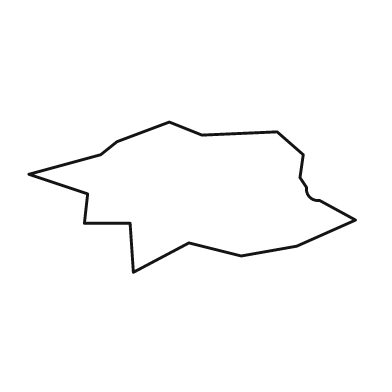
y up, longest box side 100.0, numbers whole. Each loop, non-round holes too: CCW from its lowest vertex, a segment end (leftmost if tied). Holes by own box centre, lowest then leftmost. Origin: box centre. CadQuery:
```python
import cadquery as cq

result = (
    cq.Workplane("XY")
    .moveTo(-18.0, -23.0)
    .lineTo(-1.0, -14.0)
    .lineTo(15.0, -18.0)
    .lineTo(32.0, -15.0)
    .lineTo(50.0, -7.0)
    .lineTo(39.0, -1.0)
    .threePointArc((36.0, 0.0), (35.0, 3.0))
    .lineTo(33.0, 6.0)
    .lineTo(34.0, 13.0)
    .lineTo(26.0, 20.0)
    .lineTo(3.0, 19.0)
    .lineTo(-7.0, 23.0)
    .lineTo(-23.0, 17.0)
    .lineTo(-28.0, 13.0)
    .lineTo(-50.0, 7.0)
    .lineTo(-32.0, 1.0)
    .lineTo(-33.0, -8.0)
    .lineTo(-19.0, -8.0)
    .close()
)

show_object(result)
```